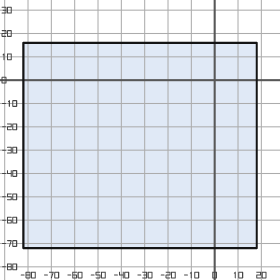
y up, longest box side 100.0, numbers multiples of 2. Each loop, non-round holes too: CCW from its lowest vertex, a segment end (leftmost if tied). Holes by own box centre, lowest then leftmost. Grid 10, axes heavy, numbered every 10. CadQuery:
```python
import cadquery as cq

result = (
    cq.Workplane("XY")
    .moveTo(-82.0, -72.0)
    .lineTo(18.0, -72.0)
    .lineTo(18.0, 16.0)
    .lineTo(-82.0, 16.0)
    .close()
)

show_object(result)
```